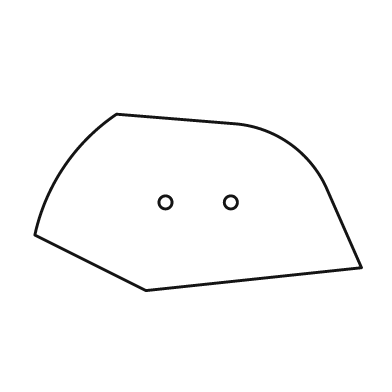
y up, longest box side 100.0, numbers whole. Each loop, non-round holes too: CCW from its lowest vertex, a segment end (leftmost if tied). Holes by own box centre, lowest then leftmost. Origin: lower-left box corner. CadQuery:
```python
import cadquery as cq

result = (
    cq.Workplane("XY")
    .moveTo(34.0, 0.0)
    .lineTo(100.0, 7.0)
    .lineTo(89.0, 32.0)
    .threePointArc((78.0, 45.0), (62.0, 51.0))
    .lineTo(25.0, 54.0)
    .threePointArc((9.0, 38.0), (0.0, 17.0))
    .close()
    .moveTo(40.0, 27.0)
    .circle(2.0)
    .moveTo(60.0, 27.0)
    .circle(2.0)
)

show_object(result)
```